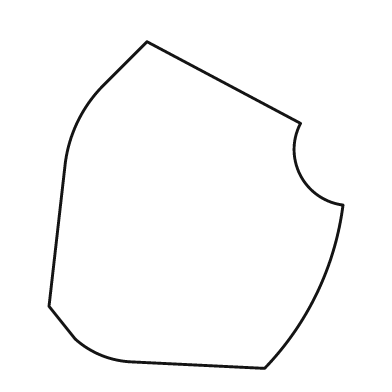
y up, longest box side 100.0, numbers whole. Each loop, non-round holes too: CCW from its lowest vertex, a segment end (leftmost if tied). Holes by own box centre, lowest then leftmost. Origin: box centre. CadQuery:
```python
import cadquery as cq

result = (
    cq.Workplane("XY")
    .moveTo(21.0, -50.0)
    .threePointArc((37.0, -27.0), (45.0, 0.0))
    .threePointArc((32.0, 9.0), (32.0, 25.0))
    .lineTo(-15.0, 50.0)
    .lineTo(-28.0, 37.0)
    .threePointArc((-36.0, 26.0), (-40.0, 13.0))
    .lineTo(-45.0, -31.0)
    .lineTo(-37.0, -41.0)
    .threePointArc((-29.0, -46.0), (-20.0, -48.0))
    .close()
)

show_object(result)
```